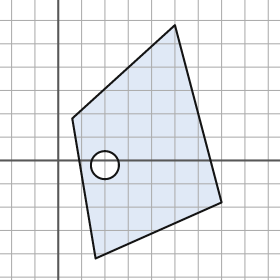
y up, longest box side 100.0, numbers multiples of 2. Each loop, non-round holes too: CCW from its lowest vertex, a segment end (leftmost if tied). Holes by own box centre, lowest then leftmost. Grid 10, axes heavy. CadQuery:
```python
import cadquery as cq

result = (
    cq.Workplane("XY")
    .moveTo(16.0, -42.0)
    .lineTo(70.0, -18.0)
    .lineTo(50.0, 58.0)
    .lineTo(6.0, 18.0)
    .close()
    .moveTo(20.0, -2.0)
    .circle(6.0)
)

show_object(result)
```